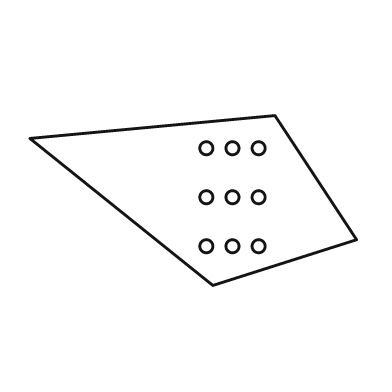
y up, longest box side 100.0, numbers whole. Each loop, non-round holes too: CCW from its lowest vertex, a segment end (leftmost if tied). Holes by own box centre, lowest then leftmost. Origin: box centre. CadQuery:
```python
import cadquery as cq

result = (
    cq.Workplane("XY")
    .moveTo(6.0, -26.0)
    .lineTo(50.0, -12.0)
    .lineTo(25.0, 26.0)
    .lineTo(-50.0, 19.0)
    .close()
    .moveTo(4.0, -14.0)
    .circle(2.0)
    .moveTo(12.0, -14.0)
    .circle(2.0)
    .moveTo(20.0, -14.0)
    .circle(2.0)
    .moveTo(4.0, 1.0)
    .circle(2.0)
    .moveTo(12.0, 1.0)
    .circle(2.0)
    .moveTo(20.0, 1.0)
    .circle(2.0)
    .moveTo(4.0, 16.0)
    .circle(2.0)
    .moveTo(12.0, 16.0)
    .circle(2.0)
    .moveTo(20.0, 16.0)
    .circle(2.0)
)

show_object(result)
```